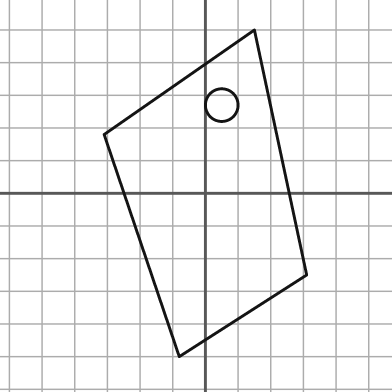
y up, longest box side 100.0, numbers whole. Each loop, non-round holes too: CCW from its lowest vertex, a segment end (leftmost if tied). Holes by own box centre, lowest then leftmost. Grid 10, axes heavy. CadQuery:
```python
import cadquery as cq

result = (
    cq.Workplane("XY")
    .moveTo(-8.0, -50.0)
    .lineTo(31.0, -25.0)
    .lineTo(15.0, 50.0)
    .lineTo(-31.0, 18.0)
    .close()
    .moveTo(5.0, 27.0)
    .circle(5.0)
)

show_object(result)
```